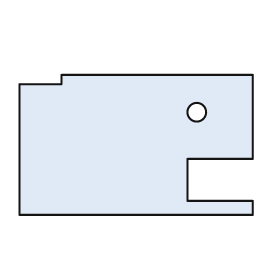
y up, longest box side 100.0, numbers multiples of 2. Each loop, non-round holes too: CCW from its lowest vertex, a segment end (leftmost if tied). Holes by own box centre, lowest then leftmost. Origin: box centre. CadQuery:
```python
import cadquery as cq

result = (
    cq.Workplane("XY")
    .moveTo(-50.0, -30.0)
    .lineTo(50.0, -30.0)
    .lineTo(50.0, -24.0)
    .lineTo(22.0, -24.0)
    .lineTo(22.0, -6.0)
    .lineTo(50.0, -6.0)
    .lineTo(50.0, 30.0)
    .lineTo(-32.0, 30.0)
    .lineTo(-32.0, 26.0)
    .lineTo(-50.0, 26.0)
    .close()
    .moveTo(26.0, 14.0)
    .circle(4.0)
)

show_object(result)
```